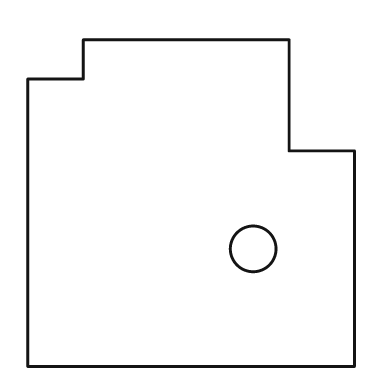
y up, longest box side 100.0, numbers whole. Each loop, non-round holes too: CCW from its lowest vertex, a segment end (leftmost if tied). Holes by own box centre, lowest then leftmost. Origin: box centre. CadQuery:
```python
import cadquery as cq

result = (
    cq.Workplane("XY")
    .moveTo(-50.0, -50.0)
    .lineTo(50.0, -50.0)
    .lineTo(50.0, 16.0)
    .lineTo(30.0, 16.0)
    .lineTo(30.0, 50.0)
    .lineTo(-33.0, 50.0)
    .lineTo(-33.0, 38.0)
    .lineTo(-50.0, 38.0)
    .close()
    .moveTo(19.0, -14.0)
    .circle(7.0)
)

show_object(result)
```